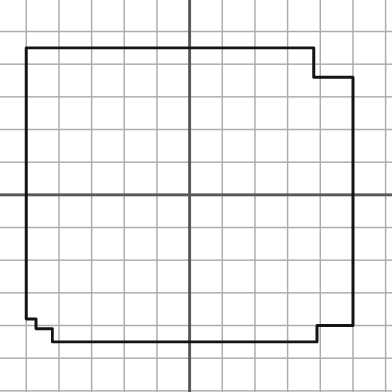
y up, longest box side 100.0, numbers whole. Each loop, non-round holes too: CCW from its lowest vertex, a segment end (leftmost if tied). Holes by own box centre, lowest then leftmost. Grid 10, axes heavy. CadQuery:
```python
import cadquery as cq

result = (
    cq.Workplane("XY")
    .moveTo(-42.0, -45.0)
    .lineTo(39.0, -45.0)
    .lineTo(39.0, -40.0)
    .lineTo(50.0, -40.0)
    .lineTo(50.0, 36.0)
    .lineTo(38.0, 36.0)
    .lineTo(38.0, 45.0)
    .lineTo(-50.0, 45.0)
    .lineTo(-50.0, -38.0)
    .lineTo(-47.0, -38.0)
    .lineTo(-47.0, -41.0)
    .lineTo(-42.0, -41.0)
    .close()
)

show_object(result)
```